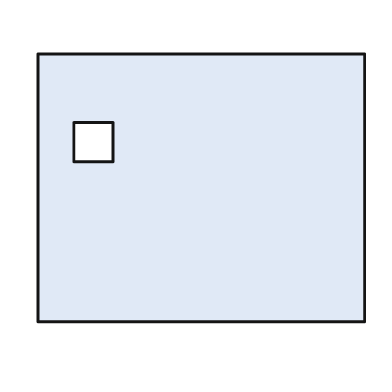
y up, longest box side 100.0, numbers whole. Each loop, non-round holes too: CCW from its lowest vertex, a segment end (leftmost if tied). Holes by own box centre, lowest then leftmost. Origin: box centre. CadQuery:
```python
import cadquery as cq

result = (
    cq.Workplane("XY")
    .moveTo(-50.0, -41.0)
    .lineTo(50.0, -41.0)
    .lineTo(50.0, 41.0)
    .lineTo(-50.0, 41.0)
    .close()
    .moveTo(-39.0, 8.0)
    .lineTo(-27.0, 8.0)
    .lineTo(-27.0, 20.0)
    .lineTo(-39.0, 20.0)
    .close()
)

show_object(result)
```